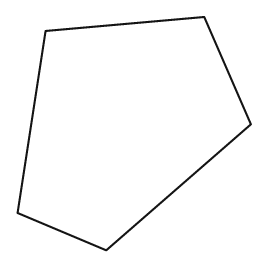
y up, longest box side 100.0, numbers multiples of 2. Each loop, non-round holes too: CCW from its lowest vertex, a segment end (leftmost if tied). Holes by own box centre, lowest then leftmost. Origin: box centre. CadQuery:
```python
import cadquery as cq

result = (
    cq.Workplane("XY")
    .moveTo(-12.0, -50.0)
    .lineTo(50.0, 4.0)
    .lineTo(30.0, 50.0)
    .lineTo(-38.0, 44.0)
    .lineTo(-50.0, -34.0)
    .close()
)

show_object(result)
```